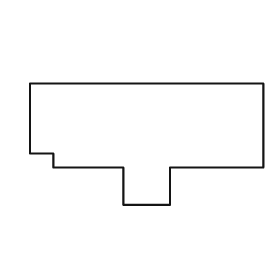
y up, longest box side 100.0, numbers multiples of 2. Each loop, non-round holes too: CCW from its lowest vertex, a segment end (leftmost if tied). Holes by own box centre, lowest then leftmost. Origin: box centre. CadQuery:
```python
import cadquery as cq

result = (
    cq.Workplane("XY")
    .moveTo(-10.0, -26.0)
    .lineTo(10.0, -26.0)
    .lineTo(10.0, -10.0)
    .lineTo(50.0, -10.0)
    .lineTo(50.0, 26.0)
    .lineTo(-50.0, 26.0)
    .lineTo(-50.0, -4.0)
    .lineTo(-40.0, -4.0)
    .lineTo(-40.0, -10.0)
    .lineTo(-10.0, -10.0)
    .close()
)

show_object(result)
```